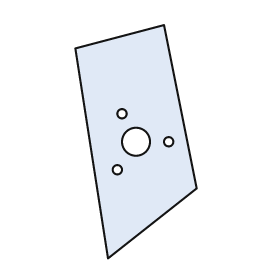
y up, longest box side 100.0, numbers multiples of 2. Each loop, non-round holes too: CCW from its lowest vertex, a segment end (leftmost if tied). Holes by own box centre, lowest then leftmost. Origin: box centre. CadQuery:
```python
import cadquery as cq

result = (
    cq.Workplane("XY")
    .moveTo(-12.0, -50.0)
    .lineTo(26.0, -20.0)
    .lineTo(12.0, 50.0)
    .lineTo(-26.0, 40.0)
    .close()
    .moveTo(-8.0, -12.0)
    .circle(2.0)
    .moveTo(0.0, 0.0)
    .circle(6.0)
    .moveTo(14.0, 0.0)
    .circle(2.0)
    .moveTo(-6.0, 12.0)
    .circle(2.0)
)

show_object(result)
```